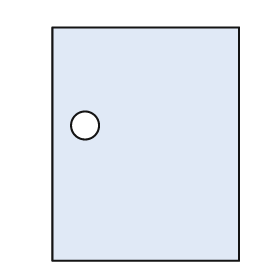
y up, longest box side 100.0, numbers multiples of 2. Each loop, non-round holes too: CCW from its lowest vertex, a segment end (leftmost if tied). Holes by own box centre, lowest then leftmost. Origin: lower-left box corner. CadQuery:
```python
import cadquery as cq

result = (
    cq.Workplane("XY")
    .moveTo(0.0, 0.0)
    .lineTo(80.0, 0.0)
    .lineTo(80.0, 100.0)
    .lineTo(0.0, 100.0)
    .close()
    .moveTo(14.0, 58.0)
    .circle(6.0)
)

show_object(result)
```